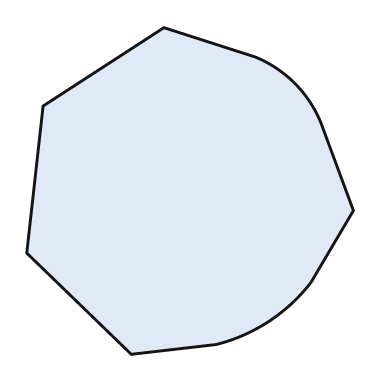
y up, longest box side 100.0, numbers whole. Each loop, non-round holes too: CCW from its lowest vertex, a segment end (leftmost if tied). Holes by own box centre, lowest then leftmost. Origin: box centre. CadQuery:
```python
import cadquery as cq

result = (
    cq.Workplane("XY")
    .moveTo(-18.0, -50.0)
    .lineTo(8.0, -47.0)
    .threePointArc((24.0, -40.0), (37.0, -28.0))
    .lineTo(50.0, -6.0)
    .lineTo(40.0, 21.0)
    .threePointArc((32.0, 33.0), (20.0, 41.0))
    .lineTo(-8.0, 50.0)
    .lineTo(-45.0, 26.0)
    .lineTo(-50.0, -19.0)
    .close()
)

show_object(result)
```